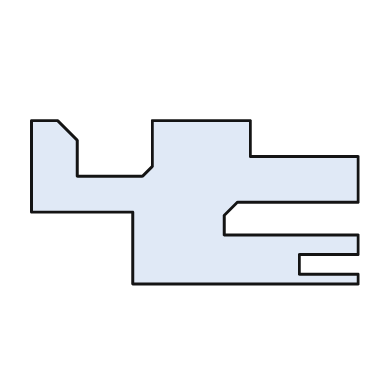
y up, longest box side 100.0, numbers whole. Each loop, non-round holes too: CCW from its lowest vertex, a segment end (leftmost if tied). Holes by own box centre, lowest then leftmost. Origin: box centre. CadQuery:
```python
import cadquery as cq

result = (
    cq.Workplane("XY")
    .moveTo(-19.0, -25.0)
    .lineTo(50.0, -25.0)
    .lineTo(50.0, -22.0)
    .lineTo(32.0, -22.0)
    .lineTo(32.0, -16.0)
    .lineTo(50.0, -16.0)
    .lineTo(50.0, -10.0)
    .lineTo(9.0, -10.0)
    .lineTo(9.0, -4.0)
    .lineTo(13.0, 0.0)
    .lineTo(50.0, 0.0)
    .lineTo(50.0, 14.0)
    .lineTo(17.0, 14.0)
    .lineTo(17.0, 25.0)
    .lineTo(-13.0, 25.0)
    .lineTo(-13.0, 11.0)
    .lineTo(-16.0, 8.0)
    .lineTo(-36.0, 8.0)
    .lineTo(-36.0, 19.0)
    .lineTo(-42.0, 25.0)
    .lineTo(-50.0, 25.0)
    .lineTo(-50.0, -3.0)
    .lineTo(-19.0, -3.0)
    .close()
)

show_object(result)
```